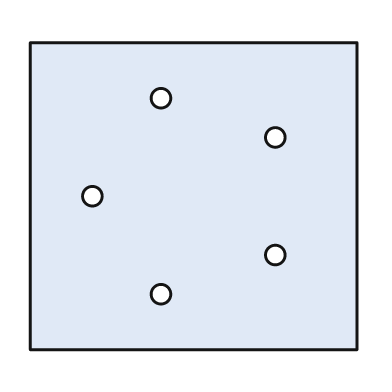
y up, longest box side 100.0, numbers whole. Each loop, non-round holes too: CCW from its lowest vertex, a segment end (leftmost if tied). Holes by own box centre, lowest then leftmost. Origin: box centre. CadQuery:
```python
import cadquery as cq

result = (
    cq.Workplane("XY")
    .moveTo(-50.0, -47.0)
    .lineTo(50.0, -47.0)
    .lineTo(50.0, 47.0)
    .lineTo(-50.0, 47.0)
    .close()
    .moveTo(-10.0, -30.0)
    .circle(3.0)
    .moveTo(25.0, -18.0)
    .circle(3.0)
    .moveTo(-31.0, 0.0)
    .circle(3.0)
    .moveTo(25.0, 18.0)
    .circle(3.0)
    .moveTo(-10.0, 30.0)
    .circle(3.0)
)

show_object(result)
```